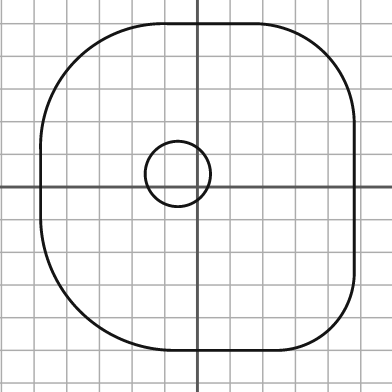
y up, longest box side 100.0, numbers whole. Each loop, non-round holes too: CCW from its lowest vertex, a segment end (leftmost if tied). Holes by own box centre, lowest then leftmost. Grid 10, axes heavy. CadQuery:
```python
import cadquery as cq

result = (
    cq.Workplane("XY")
    .moveTo(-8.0, -50.0)
    .lineTo(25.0, -50.0)
    .threePointArc((41.0, -43.0), (48.0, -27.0))
    .lineTo(48.0, 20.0)
    .threePointArc((39.0, 41.0), (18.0, 50.0))
    .lineTo(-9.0, 50.0)
    .threePointArc((-37.0, 39.0), (-48.0, 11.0))
    .lineTo(-48.0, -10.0)
    .threePointArc((-36.0, -38.0), (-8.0, -50.0))
    .close()
    .moveTo(-6.0, 4.0)
    .circle(10.0)
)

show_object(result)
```